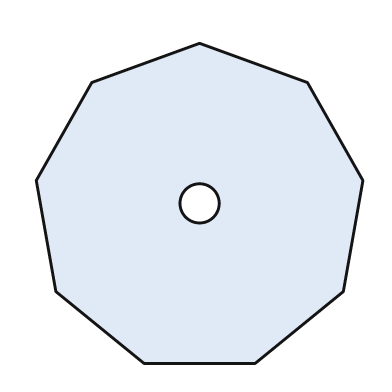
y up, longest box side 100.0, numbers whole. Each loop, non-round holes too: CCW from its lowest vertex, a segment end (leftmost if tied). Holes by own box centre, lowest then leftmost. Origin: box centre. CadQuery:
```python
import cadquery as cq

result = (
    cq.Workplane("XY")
    .moveTo(-17.0, -49.0)
    .lineTo(17.0, -49.0)
    .lineTo(44.0, -27.0)
    .lineTo(50.0, 7.0)
    .lineTo(33.0, 37.0)
    .lineTo(0.0, 49.0)
    .lineTo(-33.0, 37.0)
    .lineTo(-50.0, 7.0)
    .lineTo(-44.0, -27.0)
    .close()
    .moveTo(0.0, 0.0)
    .circle(6.0)
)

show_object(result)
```